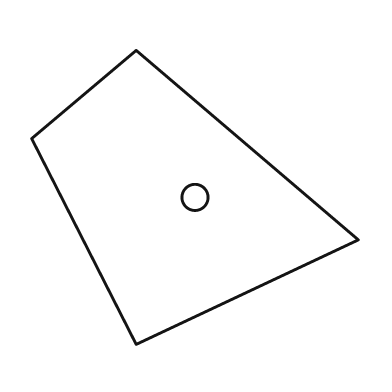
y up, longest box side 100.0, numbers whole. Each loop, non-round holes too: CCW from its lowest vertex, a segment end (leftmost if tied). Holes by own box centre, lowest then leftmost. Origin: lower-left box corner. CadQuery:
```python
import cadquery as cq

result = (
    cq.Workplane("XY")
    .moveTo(32.0, 0.0)
    .lineTo(100.0, 32.0)
    .lineTo(32.0, 90.0)
    .lineTo(0.0, 63.0)
    .close()
    .moveTo(50.0, 45.0)
    .circle(4.0)
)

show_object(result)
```